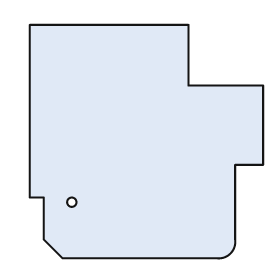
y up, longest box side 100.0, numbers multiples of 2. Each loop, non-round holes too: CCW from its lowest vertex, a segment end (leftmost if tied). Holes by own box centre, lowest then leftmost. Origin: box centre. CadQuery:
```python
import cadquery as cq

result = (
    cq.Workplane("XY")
    .moveTo(-36.0, -50.0)
    .lineTo(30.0, -50.0)
    .threePointArc((36.0, -48.0), (38.0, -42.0))
    .lineTo(38.0, -10.0)
    .lineTo(50.0, -10.0)
    .lineTo(50.0, 24.0)
    .lineTo(18.0, 24.0)
    .lineTo(18.0, 50.0)
    .lineTo(-50.0, 50.0)
    .lineTo(-50.0, -24.0)
    .lineTo(-44.0, -24.0)
    .lineTo(-44.0, -42.0)
    .close()
    .moveTo(-32.0, -26.0)
    .circle(2.0)
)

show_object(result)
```